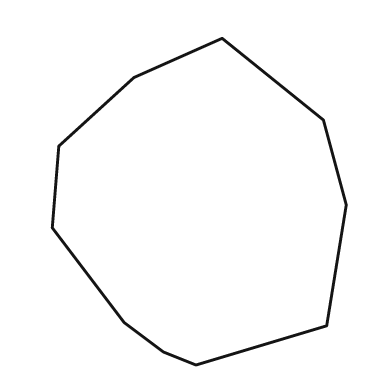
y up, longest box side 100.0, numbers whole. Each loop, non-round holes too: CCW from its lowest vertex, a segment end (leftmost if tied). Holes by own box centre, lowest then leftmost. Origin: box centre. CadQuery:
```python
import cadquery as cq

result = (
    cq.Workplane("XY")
    .moveTo(-1.0, -50.0)
    .lineTo(39.0, -38.0)
    .lineTo(45.0, -1.0)
    .lineTo(38.0, 25.0)
    .lineTo(7.0, 50.0)
    .lineTo(-20.0, 38.0)
    .lineTo(-43.0, 17.0)
    .lineTo(-45.0, -8.0)
    .lineTo(-23.0, -37.0)
    .lineTo(-11.0, -46.0)
    .close()
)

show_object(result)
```